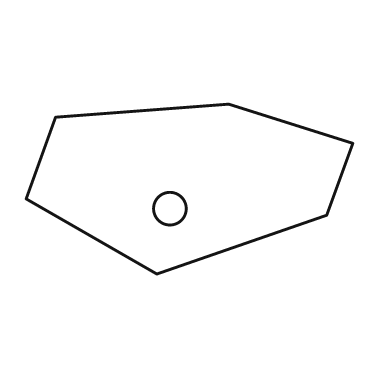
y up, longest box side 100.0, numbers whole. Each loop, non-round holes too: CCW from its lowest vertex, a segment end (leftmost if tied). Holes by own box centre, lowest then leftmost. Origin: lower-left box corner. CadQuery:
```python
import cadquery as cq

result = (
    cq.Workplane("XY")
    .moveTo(40.0, 0.0)
    .lineTo(92.0, 18.0)
    .lineTo(100.0, 40.0)
    .lineTo(62.0, 52.0)
    .lineTo(9.0, 48.0)
    .lineTo(0.0, 23.0)
    .close()
    .moveTo(44.0, 20.0)
    .circle(5.0)
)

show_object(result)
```